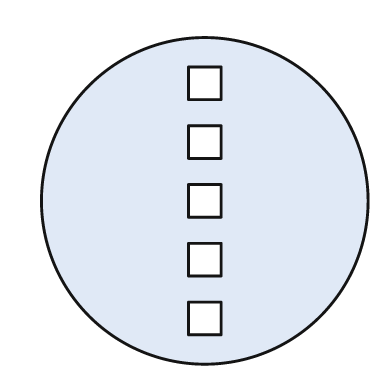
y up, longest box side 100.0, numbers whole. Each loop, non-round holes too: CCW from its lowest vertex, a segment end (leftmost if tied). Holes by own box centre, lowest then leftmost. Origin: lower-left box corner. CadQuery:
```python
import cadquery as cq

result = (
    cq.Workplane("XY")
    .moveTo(50.0, 50.0)
    .circle(50.0)
    .moveTo(45.0, 9.0)
    .lineTo(55.0, 9.0)
    .lineTo(55.0, 19.0)
    .lineTo(45.0, 19.0)
    .close()
    .moveTo(45.0, 27.0)
    .lineTo(55.0, 27.0)
    .lineTo(55.0, 37.0)
    .lineTo(45.0, 37.0)
    .close()
    .moveTo(45.0, 45.0)
    .lineTo(55.0, 45.0)
    .lineTo(55.0, 55.0)
    .lineTo(45.0, 55.0)
    .close()
    .moveTo(45.0, 63.0)
    .lineTo(55.0, 63.0)
    .lineTo(55.0, 73.0)
    .lineTo(45.0, 73.0)
    .close()
    .moveTo(45.0, 81.0)
    .lineTo(55.0, 81.0)
    .lineTo(55.0, 91.0)
    .lineTo(45.0, 91.0)
    .close()
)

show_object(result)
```